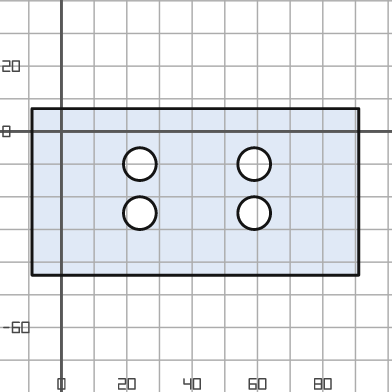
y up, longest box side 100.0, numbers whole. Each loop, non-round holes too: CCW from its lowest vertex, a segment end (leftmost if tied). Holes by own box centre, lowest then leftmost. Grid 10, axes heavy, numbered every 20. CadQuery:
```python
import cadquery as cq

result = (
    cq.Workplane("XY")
    .moveTo(-9.0, -44.0)
    .lineTo(91.0, -44.0)
    .lineTo(91.0, 7.0)
    .lineTo(-9.0, 7.0)
    .close()
    .moveTo(24.0, -25.0)
    .circle(5.0)
    .moveTo(59.0, -25.0)
    .circle(5.0)
    .moveTo(24.0, -10.0)
    .circle(5.0)
    .moveTo(59.0, -10.0)
    .circle(5.0)
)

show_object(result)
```